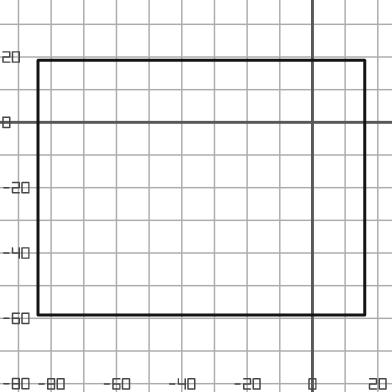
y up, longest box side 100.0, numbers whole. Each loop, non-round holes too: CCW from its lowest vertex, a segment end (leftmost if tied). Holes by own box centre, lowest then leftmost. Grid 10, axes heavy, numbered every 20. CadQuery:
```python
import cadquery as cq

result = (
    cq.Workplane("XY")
    .moveTo(-84.0, -59.0)
    .lineTo(16.0, -59.0)
    .lineTo(16.0, 19.0)
    .lineTo(-84.0, 19.0)
    .close()
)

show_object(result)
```